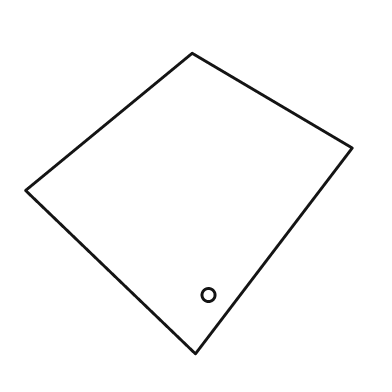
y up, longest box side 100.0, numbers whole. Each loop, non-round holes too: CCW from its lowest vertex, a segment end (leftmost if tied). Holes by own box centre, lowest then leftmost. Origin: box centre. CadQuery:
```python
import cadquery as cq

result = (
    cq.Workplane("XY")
    .moveTo(2.0, -46.0)
    .lineTo(50.0, 17.0)
    .lineTo(1.0, 46.0)
    .lineTo(-50.0, 4.0)
    .close()
    .moveTo(6.0, -28.0)
    .circle(2.0)
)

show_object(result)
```